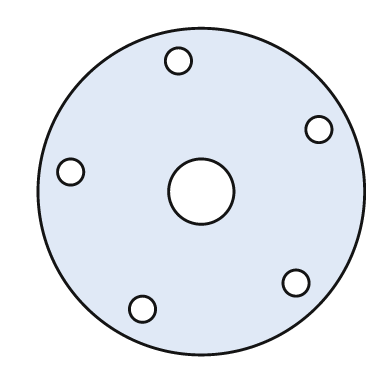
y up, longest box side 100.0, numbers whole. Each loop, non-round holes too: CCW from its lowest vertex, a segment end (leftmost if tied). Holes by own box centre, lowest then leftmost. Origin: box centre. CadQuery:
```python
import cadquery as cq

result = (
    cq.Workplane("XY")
    .moveTo(0.0, 0.0)
    .circle(50.0)
    .moveTo(-18.0, -36.0)
    .circle(4.0)
    .moveTo(29.0, -28.0)
    .circle(4.0)
    .moveTo(0.0, 0.0)
    .circle(10.0)
    .moveTo(-40.0, 6.0)
    .circle(4.0)
    .moveTo(36.0, 19.0)
    .circle(4.0)
    .moveTo(-7.0, 40.0)
    .circle(4.0)
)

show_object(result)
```